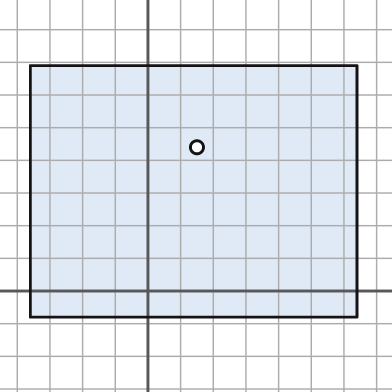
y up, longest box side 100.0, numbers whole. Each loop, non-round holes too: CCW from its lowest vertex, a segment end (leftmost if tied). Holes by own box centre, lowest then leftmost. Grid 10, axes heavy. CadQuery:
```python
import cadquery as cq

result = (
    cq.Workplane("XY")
    .moveTo(-36.0, -8.0)
    .lineTo(64.0, -8.0)
    .lineTo(64.0, 69.0)
    .lineTo(-36.0, 69.0)
    .close()
    .moveTo(15.0, 44.0)
    .circle(2.0)
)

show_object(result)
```